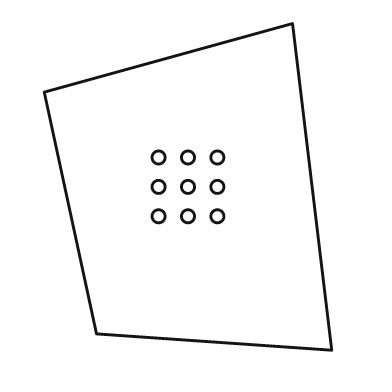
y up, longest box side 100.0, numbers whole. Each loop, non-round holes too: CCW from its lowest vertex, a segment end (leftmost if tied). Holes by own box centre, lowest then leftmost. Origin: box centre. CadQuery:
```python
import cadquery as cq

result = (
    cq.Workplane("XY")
    .moveTo(44.0, -50.0)
    .lineTo(32.0, 50.0)
    .lineTo(-44.0, 29.0)
    .lineTo(-28.0, -45.0)
    .close()
    .moveTo(-9.0, -9.0)
    .circle(2.0)
    .moveTo(0.0, -9.0)
    .circle(2.0)
    .moveTo(9.0, -9.0)
    .circle(2.0)
    .moveTo(-9.0, 0.0)
    .circle(2.0)
    .moveTo(0.0, 0.0)
    .circle(2.0)
    .moveTo(9.0, 0.0)
    .circle(2.0)
    .moveTo(-9.0, 9.0)
    .circle(2.0)
    .moveTo(0.0, 9.0)
    .circle(2.0)
    .moveTo(9.0, 9.0)
    .circle(2.0)
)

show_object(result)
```